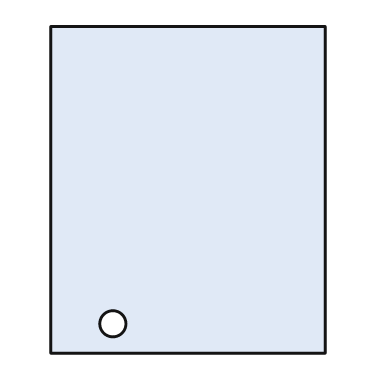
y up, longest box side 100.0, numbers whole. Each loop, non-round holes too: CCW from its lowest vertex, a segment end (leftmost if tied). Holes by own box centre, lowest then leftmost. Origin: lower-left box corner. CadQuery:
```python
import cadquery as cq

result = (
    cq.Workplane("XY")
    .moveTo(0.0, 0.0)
    .lineTo(84.0, 0.0)
    .lineTo(84.0, 100.0)
    .lineTo(0.0, 100.0)
    .close()
    .moveTo(19.0, 9.0)
    .circle(4.0)
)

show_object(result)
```